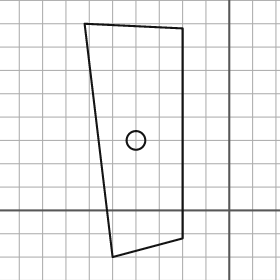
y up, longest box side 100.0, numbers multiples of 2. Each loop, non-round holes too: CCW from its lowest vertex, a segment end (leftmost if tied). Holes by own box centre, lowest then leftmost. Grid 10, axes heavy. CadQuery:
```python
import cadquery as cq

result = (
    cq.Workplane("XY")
    .moveTo(-50.0, -20.0)
    .lineTo(-20.0, -12.0)
    .lineTo(-20.0, 78.0)
    .lineTo(-62.0, 80.0)
    .close()
    .moveTo(-40.0, 30.0)
    .circle(4.0)
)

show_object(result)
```